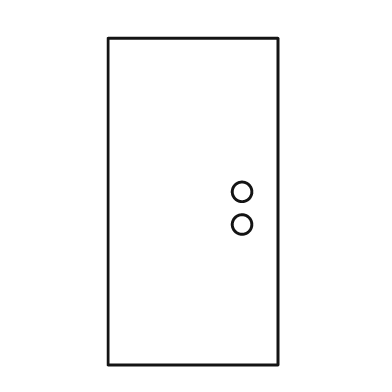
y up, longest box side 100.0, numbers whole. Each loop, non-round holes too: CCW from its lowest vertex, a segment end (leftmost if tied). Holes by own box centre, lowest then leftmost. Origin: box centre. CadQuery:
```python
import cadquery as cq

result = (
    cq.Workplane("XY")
    .moveTo(-26.0, -50.0)
    .lineTo(26.0, -50.0)
    .lineTo(26.0, 50.0)
    .lineTo(-26.0, 50.0)
    .close()
    .moveTo(15.0, -7.0)
    .circle(3.0)
    .moveTo(15.0, 3.0)
    .circle(3.0)
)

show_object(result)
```